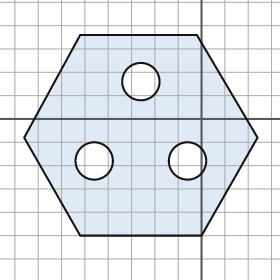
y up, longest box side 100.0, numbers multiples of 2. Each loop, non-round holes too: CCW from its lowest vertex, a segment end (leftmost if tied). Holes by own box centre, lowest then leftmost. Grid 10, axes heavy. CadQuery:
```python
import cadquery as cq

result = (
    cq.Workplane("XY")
    .moveTo(-52.0, -50.0)
    .lineTo(0.0, -50.0)
    .lineTo(24.0, -8.0)
    .lineTo(-2.0, 36.0)
    .lineTo(-52.0, 36.0)
    .lineTo(-76.0, -8.0)
    .close()
    .moveTo(-46.0, -18.0)
    .circle(8.0)
    .moveTo(-6.0, -18.0)
    .circle(8.0)
    .moveTo(-26.0, 16.0)
    .circle(8.0)
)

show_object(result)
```